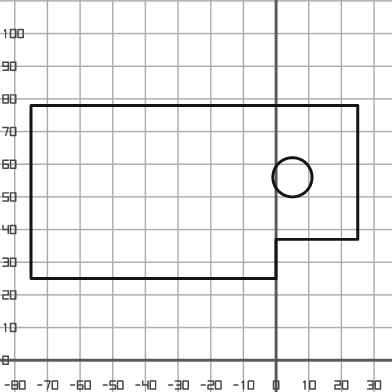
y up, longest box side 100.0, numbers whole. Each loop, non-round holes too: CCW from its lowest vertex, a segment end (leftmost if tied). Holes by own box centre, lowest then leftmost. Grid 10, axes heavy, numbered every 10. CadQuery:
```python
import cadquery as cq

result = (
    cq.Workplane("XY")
    .moveTo(-75.0, 25.0)
    .lineTo(0.0, 25.0)
    .lineTo(0.0, 37.0)
    .lineTo(25.0, 37.0)
    .lineTo(25.0, 78.0)
    .lineTo(-75.0, 78.0)
    .close()
    .moveTo(5.0, 56.0)
    .circle(6.0)
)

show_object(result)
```